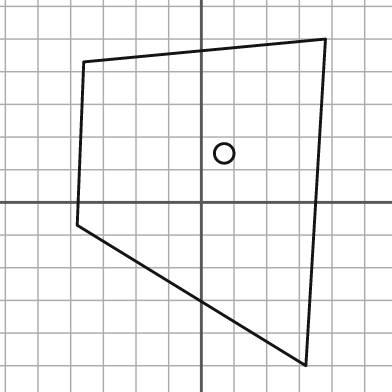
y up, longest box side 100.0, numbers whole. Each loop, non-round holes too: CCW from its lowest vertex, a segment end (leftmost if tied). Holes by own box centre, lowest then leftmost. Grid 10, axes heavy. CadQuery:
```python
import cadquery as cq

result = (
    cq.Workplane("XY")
    .moveTo(32.0, -50.0)
    .lineTo(38.0, 50.0)
    .lineTo(-36.0, 43.0)
    .lineTo(-38.0, -7.0)
    .close()
    .moveTo(7.0, 15.0)
    .circle(3.0)
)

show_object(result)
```